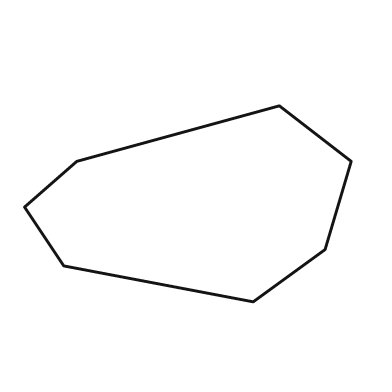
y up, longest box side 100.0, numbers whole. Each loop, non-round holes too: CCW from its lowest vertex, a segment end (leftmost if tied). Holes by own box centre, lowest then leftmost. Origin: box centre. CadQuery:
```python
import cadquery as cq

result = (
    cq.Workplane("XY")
    .moveTo(20.0, -30.0)
    .lineTo(42.0, -14.0)
    .lineTo(50.0, 13.0)
    .lineTo(28.0, 30.0)
    .lineTo(-34.0, 13.0)
    .lineTo(-50.0, -1.0)
    .lineTo(-38.0, -19.0)
    .close()
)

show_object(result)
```